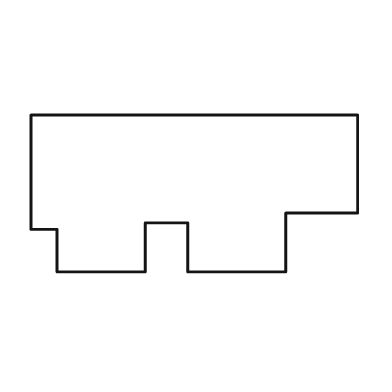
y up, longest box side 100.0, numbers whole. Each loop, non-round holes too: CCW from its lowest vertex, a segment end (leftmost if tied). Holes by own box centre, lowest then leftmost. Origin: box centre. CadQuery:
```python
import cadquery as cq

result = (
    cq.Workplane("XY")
    .moveTo(-42.0, -24.0)
    .lineTo(-15.0, -24.0)
    .lineTo(-15.0, -9.0)
    .lineTo(-2.0, -9.0)
    .lineTo(-2.0, -24.0)
    .lineTo(28.0, -24.0)
    .lineTo(28.0, -6.0)
    .lineTo(50.0, -6.0)
    .lineTo(50.0, 24.0)
    .lineTo(-50.0, 24.0)
    .lineTo(-50.0, -11.0)
    .lineTo(-42.0, -11.0)
    .close()
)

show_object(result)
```